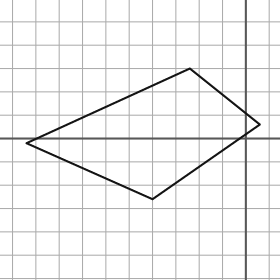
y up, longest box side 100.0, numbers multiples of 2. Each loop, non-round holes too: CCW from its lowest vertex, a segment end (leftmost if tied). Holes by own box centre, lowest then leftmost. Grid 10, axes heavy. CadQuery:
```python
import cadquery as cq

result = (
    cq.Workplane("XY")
    .moveTo(-40.0, -26.0)
    .lineTo(6.0, 6.0)
    .lineTo(-24.0, 30.0)
    .lineTo(-94.0, -2.0)
    .close()
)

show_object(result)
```